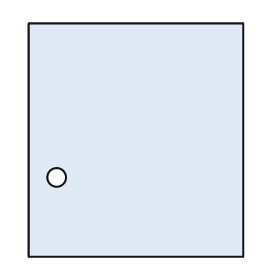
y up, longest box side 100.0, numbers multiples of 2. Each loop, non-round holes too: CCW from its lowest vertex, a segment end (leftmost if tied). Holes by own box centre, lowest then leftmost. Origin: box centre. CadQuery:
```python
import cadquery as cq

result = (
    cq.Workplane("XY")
    .moveTo(-46.0, -50.0)
    .lineTo(46.0, -50.0)
    .lineTo(46.0, 50.0)
    .lineTo(-46.0, 50.0)
    .close()
    .moveTo(-34.0, -16.0)
    .circle(4.0)
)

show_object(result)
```